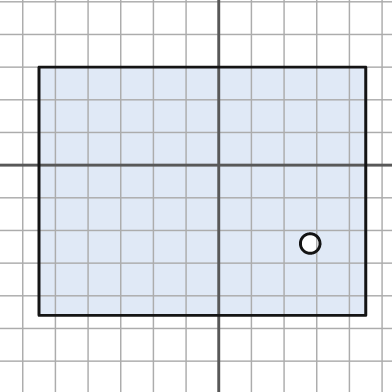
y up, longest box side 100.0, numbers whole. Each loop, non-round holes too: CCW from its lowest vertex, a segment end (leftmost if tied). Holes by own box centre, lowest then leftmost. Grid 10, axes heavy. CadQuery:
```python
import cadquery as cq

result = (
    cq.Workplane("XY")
    .moveTo(-55.0, -46.0)
    .lineTo(45.0, -46.0)
    .lineTo(45.0, 30.0)
    .lineTo(-55.0, 30.0)
    .close()
    .moveTo(28.0, -24.0)
    .circle(3.0)
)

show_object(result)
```